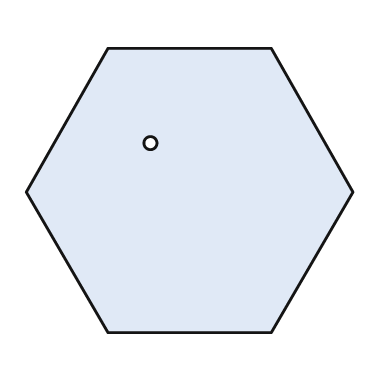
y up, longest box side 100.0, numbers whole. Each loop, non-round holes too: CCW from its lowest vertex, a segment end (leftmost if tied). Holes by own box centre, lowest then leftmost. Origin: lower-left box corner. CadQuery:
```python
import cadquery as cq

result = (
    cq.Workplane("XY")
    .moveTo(25.0, 0.0)
    .lineTo(75.0, 0.0)
    .lineTo(100.0, 43.0)
    .lineTo(75.0, 87.0)
    .lineTo(25.0, 87.0)
    .lineTo(0.0, 43.0)
    .close()
    .moveTo(38.0, 58.0)
    .circle(2.0)
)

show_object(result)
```